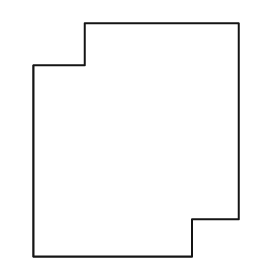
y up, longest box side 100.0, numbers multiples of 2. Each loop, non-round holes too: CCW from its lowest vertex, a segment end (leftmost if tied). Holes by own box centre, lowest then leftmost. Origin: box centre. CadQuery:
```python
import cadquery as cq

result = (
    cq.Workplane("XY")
    .moveTo(-44.0, -50.0)
    .lineTo(24.0, -50.0)
    .lineTo(24.0, -34.0)
    .lineTo(44.0, -34.0)
    .lineTo(44.0, 50.0)
    .lineTo(-22.0, 50.0)
    .lineTo(-22.0, 32.0)
    .lineTo(-44.0, 32.0)
    .close()
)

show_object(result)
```